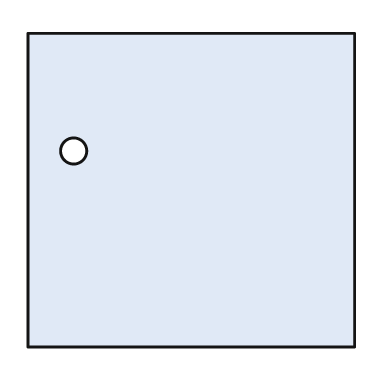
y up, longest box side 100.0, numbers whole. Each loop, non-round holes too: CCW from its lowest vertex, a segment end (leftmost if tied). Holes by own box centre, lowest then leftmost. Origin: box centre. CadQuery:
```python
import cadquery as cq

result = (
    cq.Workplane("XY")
    .moveTo(-50.0, -48.0)
    .lineTo(50.0, -48.0)
    .lineTo(50.0, 48.0)
    .lineTo(-50.0, 48.0)
    .close()
    .moveTo(-36.0, 12.0)
    .circle(4.0)
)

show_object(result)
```